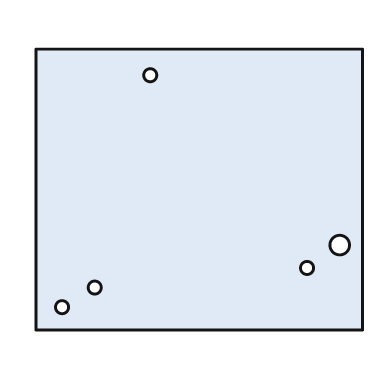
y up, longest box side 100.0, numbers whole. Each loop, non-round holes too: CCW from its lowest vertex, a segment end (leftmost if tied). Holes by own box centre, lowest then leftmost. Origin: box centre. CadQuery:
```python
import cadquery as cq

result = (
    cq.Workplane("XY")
    .moveTo(-50.0, -43.0)
    .lineTo(50.0, -43.0)
    .lineTo(50.0, 43.0)
    .lineTo(-50.0, 43.0)
    .close()
    .moveTo(-42.0, -36.0)
    .circle(2.0)
    .moveTo(-32.0, -30.0)
    .circle(2.0)
    .moveTo(33.0, -24.0)
    .circle(2.0)
    .moveTo(43.0, -17.0)
    .circle(3.0)
    .moveTo(-15.0, 35.0)
    .circle(2.0)
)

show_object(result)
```